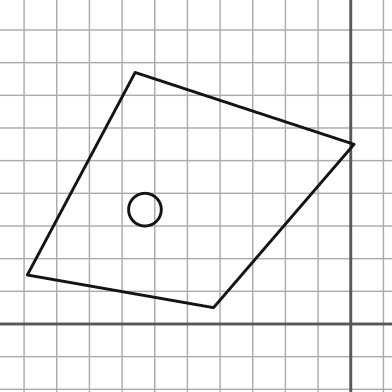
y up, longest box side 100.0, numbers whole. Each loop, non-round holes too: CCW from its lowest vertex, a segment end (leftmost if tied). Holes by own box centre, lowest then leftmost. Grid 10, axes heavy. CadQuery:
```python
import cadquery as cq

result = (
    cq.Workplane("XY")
    .moveTo(-42.0, 5.0)
    .lineTo(1.0, 55.0)
    .lineTo(-66.0, 77.0)
    .lineTo(-99.0, 15.0)
    .close()
    .moveTo(-63.0, 35.0)
    .circle(5.0)
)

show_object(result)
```